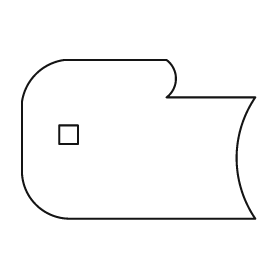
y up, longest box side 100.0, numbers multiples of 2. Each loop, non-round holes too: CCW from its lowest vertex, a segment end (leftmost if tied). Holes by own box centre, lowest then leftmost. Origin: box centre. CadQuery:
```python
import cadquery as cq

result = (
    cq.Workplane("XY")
    .moveTo(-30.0, -34.0)
    .lineTo(50.0, -34.0)
    .threePointArc((42.0, -8.0), (50.0, 18.0))
    .lineTo(12.0, 18.0)
    .threePointArc((16.0, 26.0), (12.0, 34.0))
    .lineTo(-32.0, 34.0)
    .threePointArc((-44.0, 28.0), (-50.0, 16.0))
    .lineTo(-50.0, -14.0)
    .threePointArc((-44.0, -28.0), (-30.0, -34.0))
    .close()
    .moveTo(-34.0, -2.0)
    .lineTo(-26.0, -2.0)
    .lineTo(-26.0, 6.0)
    .lineTo(-34.0, 6.0)
    .close()
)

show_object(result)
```